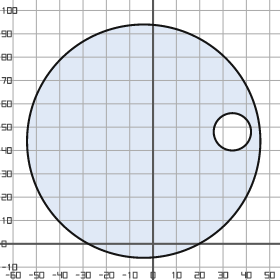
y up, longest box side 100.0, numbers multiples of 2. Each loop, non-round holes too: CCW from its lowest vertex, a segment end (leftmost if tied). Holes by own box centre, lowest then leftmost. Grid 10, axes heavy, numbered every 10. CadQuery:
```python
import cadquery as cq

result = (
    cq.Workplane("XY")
    .moveTo(-4.0, 44.0)
    .circle(50.0)
    .moveTo(34.0, 48.0)
    .circle(8.0)
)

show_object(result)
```